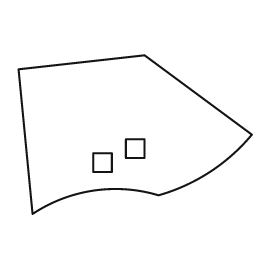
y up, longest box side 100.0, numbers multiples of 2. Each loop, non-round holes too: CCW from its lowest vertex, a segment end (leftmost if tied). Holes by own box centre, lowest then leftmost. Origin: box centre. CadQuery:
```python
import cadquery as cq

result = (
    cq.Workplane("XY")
    .moveTo(-44.0, -34.0)
    .threePointArc((-18.0, -24.0), (10.0, -26.0))
    .threePointArc((32.0, -16.0), (50.0, 0.0))
    .lineTo(4.0, 34.0)
    .lineTo(-50.0, 28.0)
    .close()
    .moveTo(-18.0, -16.0)
    .lineTo(-10.0, -16.0)
    .lineTo(-10.0, -8.0)
    .lineTo(-18.0, -8.0)
    .close()
    .moveTo(-4.0, -10.0)
    .lineTo(4.0, -10.0)
    .lineTo(4.0, -2.0)
    .lineTo(-4.0, -2.0)
    .close()
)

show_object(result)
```